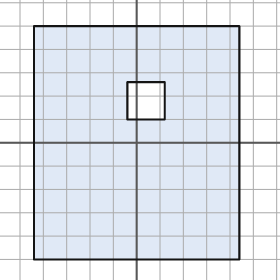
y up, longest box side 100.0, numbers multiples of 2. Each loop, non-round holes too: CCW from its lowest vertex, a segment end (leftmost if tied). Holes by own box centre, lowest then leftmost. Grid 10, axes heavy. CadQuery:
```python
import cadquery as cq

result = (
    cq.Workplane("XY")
    .moveTo(-44.0, -50.0)
    .lineTo(44.0, -50.0)
    .lineTo(44.0, 50.0)
    .lineTo(-44.0, 50.0)
    .close()
    .moveTo(-4.0, 10.0)
    .lineTo(12.0, 10.0)
    .lineTo(12.0, 26.0)
    .lineTo(-4.0, 26.0)
    .close()
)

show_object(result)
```